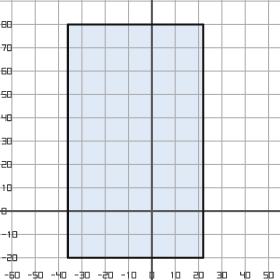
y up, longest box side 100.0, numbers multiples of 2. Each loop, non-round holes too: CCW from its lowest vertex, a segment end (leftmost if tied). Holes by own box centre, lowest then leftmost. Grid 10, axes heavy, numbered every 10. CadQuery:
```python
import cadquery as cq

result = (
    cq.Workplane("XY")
    .moveTo(-36.0, -20.0)
    .lineTo(22.0, -20.0)
    .lineTo(22.0, 80.0)
    .lineTo(-36.0, 80.0)
    .close()
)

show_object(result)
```